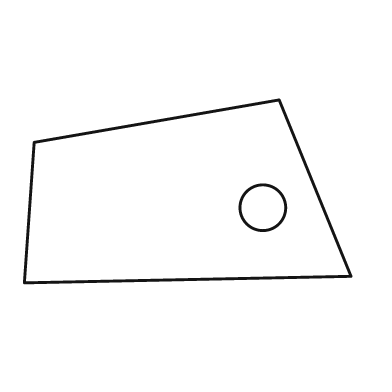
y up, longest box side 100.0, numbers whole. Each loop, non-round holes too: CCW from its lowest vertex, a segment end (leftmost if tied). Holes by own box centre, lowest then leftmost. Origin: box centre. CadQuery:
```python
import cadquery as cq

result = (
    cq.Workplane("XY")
    .moveTo(-50.0, -28.0)
    .lineTo(50.0, -26.0)
    .lineTo(28.0, 28.0)
    .lineTo(-47.0, 15.0)
    .close()
    .moveTo(23.0, -5.0)
    .circle(7.0)
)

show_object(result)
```